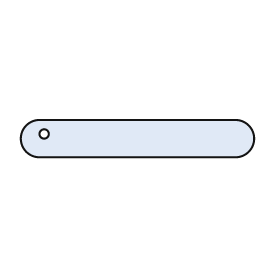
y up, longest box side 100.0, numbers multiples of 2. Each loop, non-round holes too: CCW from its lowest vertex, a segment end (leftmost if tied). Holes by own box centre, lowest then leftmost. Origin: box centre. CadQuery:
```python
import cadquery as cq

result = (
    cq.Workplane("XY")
    .moveTo(-42.0, -8.0)
    .lineTo(42.0, -8.0)
    .threePointArc((50.0, 0.0), (42.0, 8.0))
    .lineTo(-42.0, 8.0)
    .threePointArc((-50.0, 0.0), (-42.0, -8.0))
    .close()
    .moveTo(-40.0, 2.0)
    .circle(2.0)
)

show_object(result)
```